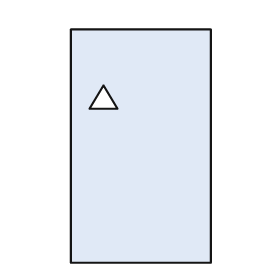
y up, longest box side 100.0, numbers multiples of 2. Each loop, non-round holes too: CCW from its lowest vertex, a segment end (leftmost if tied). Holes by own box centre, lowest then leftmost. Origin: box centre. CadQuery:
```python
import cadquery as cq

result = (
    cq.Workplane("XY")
    .moveTo(-30.0, -50.0)
    .lineTo(30.0, -50.0)
    .lineTo(30.0, 50.0)
    .lineTo(-30.0, 50.0)
    .close()
    .moveTo(-22.0, 16.0)
    .lineTo(-10.0, 16.0)
    .lineTo(-16.0, 26.0)
    .close()
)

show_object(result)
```